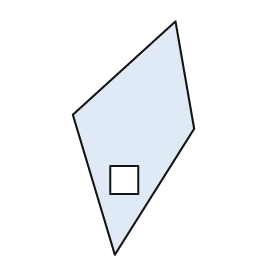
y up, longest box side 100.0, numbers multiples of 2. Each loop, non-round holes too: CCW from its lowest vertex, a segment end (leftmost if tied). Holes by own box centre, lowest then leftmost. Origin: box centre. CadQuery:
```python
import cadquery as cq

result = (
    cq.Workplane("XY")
    .moveTo(-8.0, -50.0)
    .lineTo(26.0, 4.0)
    .lineTo(18.0, 50.0)
    .lineTo(-26.0, 10.0)
    .close()
    .moveTo(-10.0, -24.0)
    .lineTo(2.0, -24.0)
    .lineTo(2.0, -12.0)
    .lineTo(-10.0, -12.0)
    .close()
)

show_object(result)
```